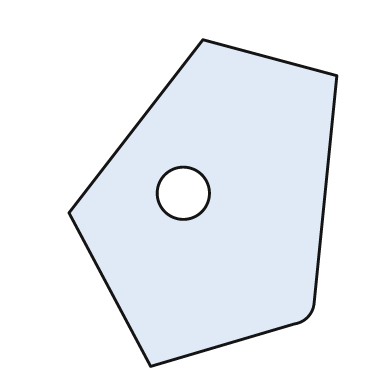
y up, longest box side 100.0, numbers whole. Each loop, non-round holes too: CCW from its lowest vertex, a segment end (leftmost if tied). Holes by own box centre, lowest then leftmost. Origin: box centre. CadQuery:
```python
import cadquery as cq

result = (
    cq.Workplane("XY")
    .moveTo(-16.0, -50.0)
    .lineTo(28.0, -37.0)
    .threePointArc((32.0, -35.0), (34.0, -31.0))
    .lineTo(41.0, 39.0)
    .lineTo(0.0, 50.0)
    .lineTo(-41.0, -3.0)
    .close()
    .moveTo(-6.0, 3.0)
    .circle(8.0)
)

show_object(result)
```